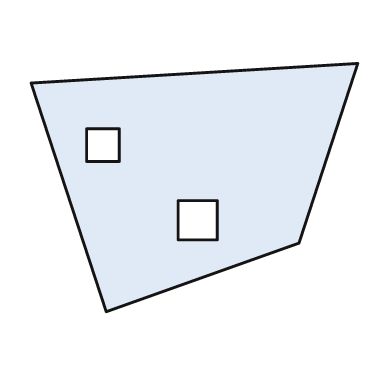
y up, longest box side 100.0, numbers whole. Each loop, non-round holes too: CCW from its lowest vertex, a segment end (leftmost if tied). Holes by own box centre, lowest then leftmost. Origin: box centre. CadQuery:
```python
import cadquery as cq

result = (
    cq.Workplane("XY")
    .moveTo(-27.0, -38.0)
    .lineTo(32.0, -17.0)
    .lineTo(50.0, 38.0)
    .lineTo(-50.0, 32.0)
    .close()
    .moveTo(-5.0, -16.0)
    .lineTo(7.0, -16.0)
    .lineTo(7.0, -4.0)
    .lineTo(-5.0, -4.0)
    .close()
    .moveTo(-33.0, 8.0)
    .lineTo(-23.0, 8.0)
    .lineTo(-23.0, 18.0)
    .lineTo(-33.0, 18.0)
    .close()
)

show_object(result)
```